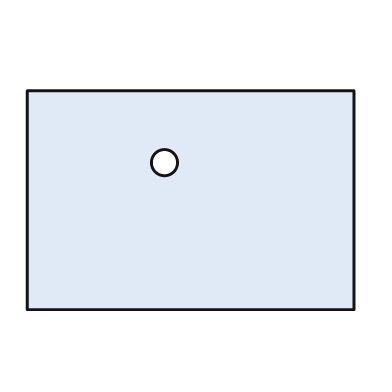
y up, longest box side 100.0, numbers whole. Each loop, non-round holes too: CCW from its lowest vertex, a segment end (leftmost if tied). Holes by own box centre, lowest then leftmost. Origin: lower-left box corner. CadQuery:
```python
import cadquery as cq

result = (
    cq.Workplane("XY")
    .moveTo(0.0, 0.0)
    .lineTo(100.0, 0.0)
    .lineTo(100.0, 67.0)
    .lineTo(0.0, 67.0)
    .close()
    .moveTo(42.0, 45.0)
    .circle(4.0)
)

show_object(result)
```